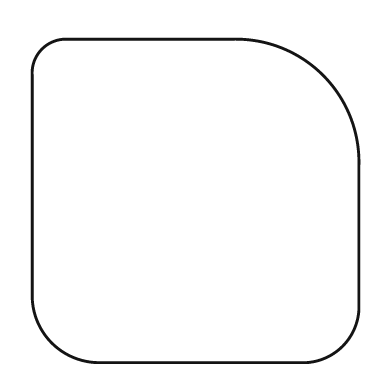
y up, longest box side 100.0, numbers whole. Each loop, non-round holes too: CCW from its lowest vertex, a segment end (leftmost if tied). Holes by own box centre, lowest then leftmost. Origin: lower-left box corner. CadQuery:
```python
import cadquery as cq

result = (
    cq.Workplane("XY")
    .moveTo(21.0, 0.0)
    .lineTo(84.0, 0.0)
    .threePointArc((95.0, 5.0), (100.0, 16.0))
    .lineTo(100.0, 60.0)
    .threePointArc((89.0, 88.0), (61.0, 99.0))
    .lineTo(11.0, 99.0)
    .threePointArc((3.0, 96.0), (0.0, 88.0))
    .lineTo(0.0, 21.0)
    .threePointArc((6.0, 6.0), (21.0, 0.0))
    .close()
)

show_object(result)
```